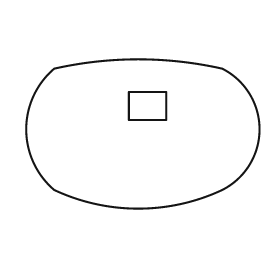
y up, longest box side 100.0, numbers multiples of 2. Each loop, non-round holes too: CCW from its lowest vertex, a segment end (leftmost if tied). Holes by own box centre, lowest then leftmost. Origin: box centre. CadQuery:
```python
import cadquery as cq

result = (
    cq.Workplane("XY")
    .moveTo(-38.0, -24.0)
    .threePointArc((-2.0, -32.0), (34.0, -24.0))
    .threePointArc((50.0, 2.0), (34.0, 28.0))
    .threePointArc((-2.0, 32.0), (-38.0, 28.0))
    .threePointArc((-50.0, 2.0), (-38.0, -24.0))
    .close()
    .moveTo(-6.0, 6.0)
    .lineTo(10.0, 6.0)
    .lineTo(10.0, 18.0)
    .lineTo(-6.0, 18.0)
    .close()
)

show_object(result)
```